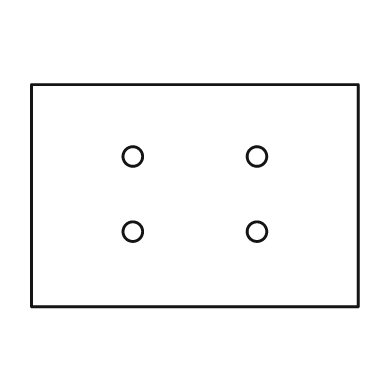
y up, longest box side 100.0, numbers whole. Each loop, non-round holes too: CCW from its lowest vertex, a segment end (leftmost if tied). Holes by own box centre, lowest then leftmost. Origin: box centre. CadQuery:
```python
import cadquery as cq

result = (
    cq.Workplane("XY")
    .moveTo(-50.0, -34.0)
    .lineTo(50.0, -34.0)
    .lineTo(50.0, 34.0)
    .lineTo(-50.0, 34.0)
    .close()
    .moveTo(-19.0, -11.0)
    .circle(3.0)
    .moveTo(19.0, -11.0)
    .circle(3.0)
    .moveTo(-19.0, 12.0)
    .circle(3.0)
    .moveTo(19.0, 12.0)
    .circle(3.0)
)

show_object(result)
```